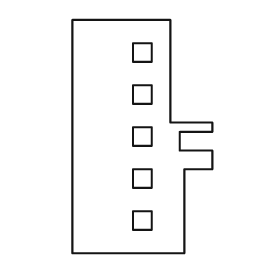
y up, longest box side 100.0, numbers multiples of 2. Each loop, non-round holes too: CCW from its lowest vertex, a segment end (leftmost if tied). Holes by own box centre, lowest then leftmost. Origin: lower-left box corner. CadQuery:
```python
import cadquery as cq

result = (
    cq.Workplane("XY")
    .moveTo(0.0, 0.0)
    .lineTo(48.0, 0.0)
    .lineTo(48.0, 36.0)
    .lineTo(60.0, 36.0)
    .lineTo(60.0, 44.0)
    .lineTo(46.0, 44.0)
    .lineTo(46.0, 52.0)
    .lineTo(60.0, 52.0)
    .lineTo(60.0, 56.0)
    .lineTo(42.0, 56.0)
    .lineTo(42.0, 100.0)
    .lineTo(0.0, 100.0)
    .close()
    .moveTo(26.0, 10.0)
    .lineTo(34.0, 10.0)
    .lineTo(34.0, 18.0)
    .lineTo(26.0, 18.0)
    .close()
    .moveTo(26.0, 28.0)
    .lineTo(34.0, 28.0)
    .lineTo(34.0, 36.0)
    .lineTo(26.0, 36.0)
    .close()
    .moveTo(26.0, 46.0)
    .lineTo(34.0, 46.0)
    .lineTo(34.0, 54.0)
    .lineTo(26.0, 54.0)
    .close()
    .moveTo(26.0, 64.0)
    .lineTo(34.0, 64.0)
    .lineTo(34.0, 72.0)
    .lineTo(26.0, 72.0)
    .close()
    .moveTo(26.0, 82.0)
    .lineTo(34.0, 82.0)
    .lineTo(34.0, 90.0)
    .lineTo(26.0, 90.0)
    .close()
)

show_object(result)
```